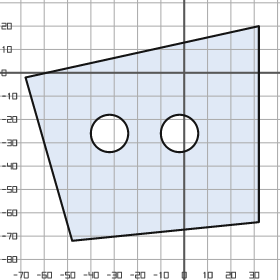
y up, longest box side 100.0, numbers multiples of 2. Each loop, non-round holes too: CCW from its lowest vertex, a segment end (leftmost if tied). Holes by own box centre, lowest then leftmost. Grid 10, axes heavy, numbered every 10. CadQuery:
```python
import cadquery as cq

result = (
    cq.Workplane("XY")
    .moveTo(-48.0, -72.0)
    .lineTo(32.0, -64.0)
    .lineTo(32.0, 20.0)
    .lineTo(-68.0, -2.0)
    .close()
    .moveTo(-32.0, -26.0)
    .circle(8.0)
    .moveTo(-2.0, -26.0)
    .circle(8.0)
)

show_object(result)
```